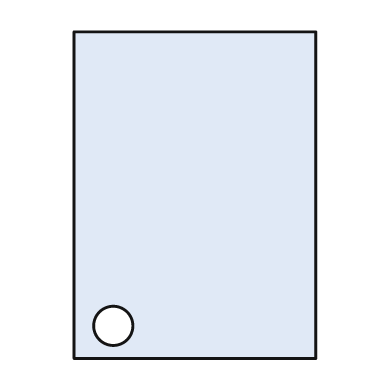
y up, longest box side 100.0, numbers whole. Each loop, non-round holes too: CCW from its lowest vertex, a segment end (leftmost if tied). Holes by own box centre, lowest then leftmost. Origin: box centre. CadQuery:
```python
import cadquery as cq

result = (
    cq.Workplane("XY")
    .moveTo(-37.0, -50.0)
    .lineTo(37.0, -50.0)
    .lineTo(37.0, 50.0)
    .lineTo(-37.0, 50.0)
    .close()
    .moveTo(-25.0, -40.0)
    .circle(6.0)
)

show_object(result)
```